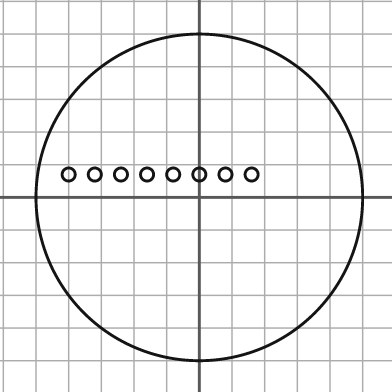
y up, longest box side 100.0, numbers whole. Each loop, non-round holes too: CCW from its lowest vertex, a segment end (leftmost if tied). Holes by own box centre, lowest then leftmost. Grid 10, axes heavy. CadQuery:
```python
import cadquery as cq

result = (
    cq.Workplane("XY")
    .moveTo(0.0, 0.0)
    .circle(50.0)
    .moveTo(-40.0, 7.0)
    .circle(2.0)
    .moveTo(-32.0, 7.0)
    .circle(2.0)
    .moveTo(-24.0, 7.0)
    .circle(2.0)
    .moveTo(-16.0, 7.0)
    .circle(2.0)
    .moveTo(-8.0, 7.0)
    .circle(2.0)
    .moveTo(0.0, 7.0)
    .circle(2.0)
    .moveTo(8.0, 7.0)
    .circle(2.0)
    .moveTo(16.0, 7.0)
    .circle(2.0)
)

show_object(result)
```